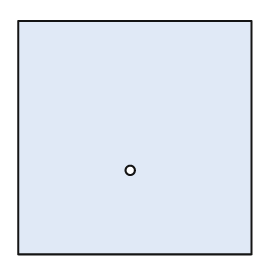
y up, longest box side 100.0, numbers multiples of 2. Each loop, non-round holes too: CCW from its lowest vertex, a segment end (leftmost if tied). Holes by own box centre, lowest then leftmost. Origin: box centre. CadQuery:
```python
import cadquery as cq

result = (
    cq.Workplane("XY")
    .moveTo(-50.0, -50.0)
    .lineTo(50.0, -50.0)
    .lineTo(50.0, 50.0)
    .lineTo(-50.0, 50.0)
    .close()
    .moveTo(-2.0, -14.0)
    .circle(2.0)
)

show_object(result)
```